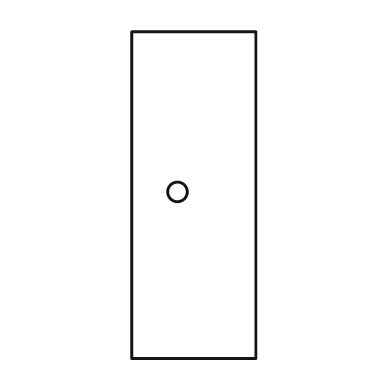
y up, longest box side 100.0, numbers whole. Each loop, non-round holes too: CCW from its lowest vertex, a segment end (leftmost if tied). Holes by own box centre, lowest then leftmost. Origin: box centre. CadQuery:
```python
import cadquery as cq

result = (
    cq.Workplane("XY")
    .moveTo(-19.0, -50.0)
    .lineTo(19.0, -50.0)
    .lineTo(19.0, 50.0)
    .lineTo(-19.0, 50.0)
    .close()
    .moveTo(-5.0, 1.0)
    .circle(3.0)
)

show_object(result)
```